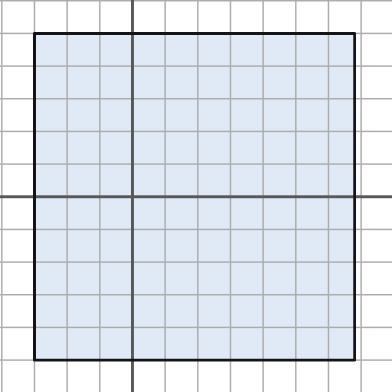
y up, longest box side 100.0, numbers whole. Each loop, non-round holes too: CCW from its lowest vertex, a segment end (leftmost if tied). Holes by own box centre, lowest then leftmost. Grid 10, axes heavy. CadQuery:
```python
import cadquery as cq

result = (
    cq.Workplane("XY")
    .moveTo(-30.0, -50.0)
    .lineTo(68.0, -50.0)
    .lineTo(68.0, 50.0)
    .lineTo(-30.0, 50.0)
    .close()
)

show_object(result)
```